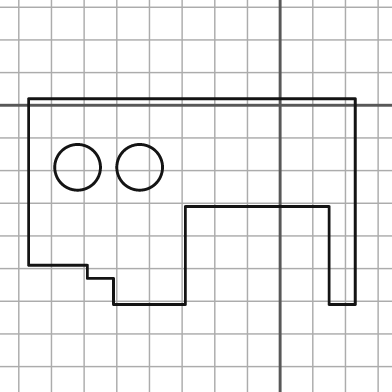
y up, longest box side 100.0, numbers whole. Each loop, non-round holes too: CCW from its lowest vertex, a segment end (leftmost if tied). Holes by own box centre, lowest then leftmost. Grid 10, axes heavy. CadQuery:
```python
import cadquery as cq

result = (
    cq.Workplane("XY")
    .moveTo(-51.0, -61.0)
    .lineTo(-29.0, -61.0)
    .lineTo(-29.0, -31.0)
    .lineTo(15.0, -31.0)
    .lineTo(15.0, -61.0)
    .lineTo(23.0, -61.0)
    .lineTo(23.0, 2.0)
    .lineTo(-77.0, 2.0)
    .lineTo(-77.0, -49.0)
    .lineTo(-59.0, -49.0)
    .lineTo(-59.0, -53.0)
    .lineTo(-51.0, -53.0)
    .close()
    .moveTo(-62.0, -19.0)
    .circle(7.0)
    .moveTo(-43.0, -19.0)
    .circle(7.0)
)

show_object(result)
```